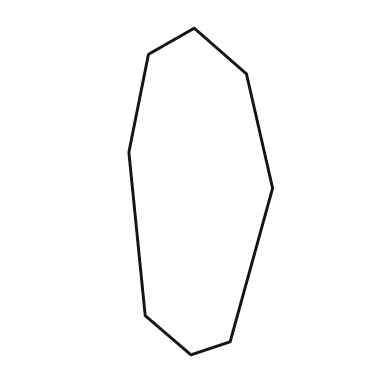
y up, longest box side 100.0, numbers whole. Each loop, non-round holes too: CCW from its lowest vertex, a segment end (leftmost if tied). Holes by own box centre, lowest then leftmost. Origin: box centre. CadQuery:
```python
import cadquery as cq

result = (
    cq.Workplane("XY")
    .moveTo(-3.0, -50.0)
    .lineTo(9.0, -46.0)
    .lineTo(22.0, 1.0)
    .lineTo(14.0, 36.0)
    .lineTo(-2.0, 50.0)
    .lineTo(-16.0, 42.0)
    .lineTo(-22.0, 12.0)
    .lineTo(-17.0, -38.0)
    .close()
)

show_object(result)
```